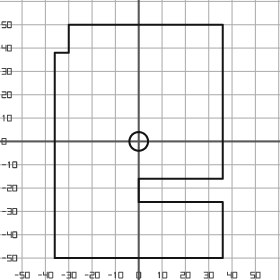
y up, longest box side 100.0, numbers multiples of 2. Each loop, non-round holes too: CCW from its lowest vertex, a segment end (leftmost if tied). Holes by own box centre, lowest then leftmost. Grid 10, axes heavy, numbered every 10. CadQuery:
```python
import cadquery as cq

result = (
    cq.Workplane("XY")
    .moveTo(-36.0, -50.0)
    .lineTo(36.0, -50.0)
    .lineTo(36.0, -26.0)
    .lineTo(0.0, -26.0)
    .lineTo(0.0, -16.0)
    .lineTo(36.0, -16.0)
    .lineTo(36.0, 50.0)
    .lineTo(-30.0, 50.0)
    .lineTo(-30.0, 38.0)
    .lineTo(-36.0, 38.0)
    .close()
    .moveTo(0.0, 0.0)
    .circle(4.0)
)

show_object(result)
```